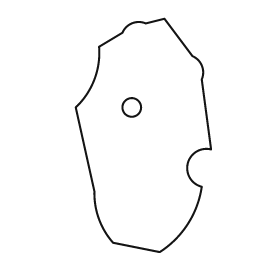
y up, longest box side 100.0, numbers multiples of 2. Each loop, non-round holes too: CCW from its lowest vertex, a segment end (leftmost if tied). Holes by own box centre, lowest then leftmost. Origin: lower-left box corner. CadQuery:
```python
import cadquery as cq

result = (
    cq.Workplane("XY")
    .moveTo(36.0, 0.0)
    .threePointArc((48.0, 12.0), (54.0, 28.0))
    .threePointArc((48.0, 38.0), (58.0, 44.0))
    .lineTo(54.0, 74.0)
    .threePointArc((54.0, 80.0), (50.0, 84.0))
    .lineTo(38.0, 100.0)
    .lineTo(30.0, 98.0)
    .threePointArc((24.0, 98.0), (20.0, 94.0))
    .lineTo(10.0, 88.0)
    .threePointArc((8.0, 74.0), (0.0, 62.0))
    .lineTo(8.0, 26.0)
    .threePointArc((10.0, 14.0), (16.0, 4.0))
    .close()
    .moveTo(24.0, 62.0)
    .circle(4.0)
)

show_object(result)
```